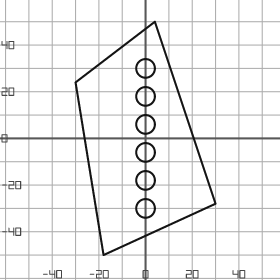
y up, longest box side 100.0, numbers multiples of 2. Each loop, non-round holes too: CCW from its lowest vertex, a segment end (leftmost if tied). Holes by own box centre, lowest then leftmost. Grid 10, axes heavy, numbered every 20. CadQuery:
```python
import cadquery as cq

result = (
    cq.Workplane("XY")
    .moveTo(-18.0, -50.0)
    .lineTo(30.0, -28.0)
    .lineTo(4.0, 50.0)
    .lineTo(-30.0, 24.0)
    .close()
    .moveTo(0.0, -30.0)
    .circle(4.0)
    .moveTo(0.0, -18.0)
    .circle(4.0)
    .moveTo(0.0, -6.0)
    .circle(4.0)
    .moveTo(0.0, 6.0)
    .circle(4.0)
    .moveTo(0.0, 18.0)
    .circle(4.0)
    .moveTo(0.0, 30.0)
    .circle(4.0)
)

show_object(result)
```